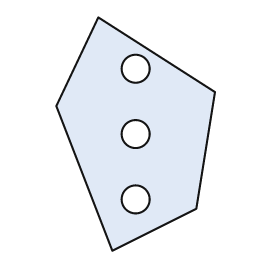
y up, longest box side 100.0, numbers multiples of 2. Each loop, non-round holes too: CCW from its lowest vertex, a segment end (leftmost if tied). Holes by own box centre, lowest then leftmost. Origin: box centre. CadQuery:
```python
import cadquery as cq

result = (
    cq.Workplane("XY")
    .moveTo(-10.0, -50.0)
    .lineTo(26.0, -32.0)
    .lineTo(34.0, 18.0)
    .lineTo(-16.0, 50.0)
    .lineTo(-34.0, 12.0)
    .close()
    .moveTo(0.0, -28.0)
    .circle(6.0)
    .moveTo(0.0, 0.0)
    .circle(6.0)
    .moveTo(0.0, 28.0)
    .circle(6.0)
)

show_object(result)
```